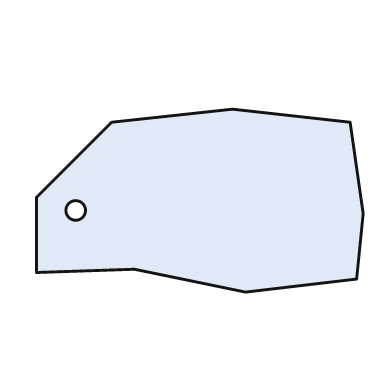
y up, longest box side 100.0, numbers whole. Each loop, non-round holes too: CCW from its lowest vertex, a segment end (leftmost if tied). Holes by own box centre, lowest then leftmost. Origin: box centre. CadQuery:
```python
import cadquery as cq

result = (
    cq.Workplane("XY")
    .moveTo(14.0, -28.0)
    .lineTo(48.0, -24.0)
    .lineTo(50.0, -4.0)
    .lineTo(46.0, 24.0)
    .lineTo(10.0, 28.0)
    .lineTo(-27.0, 24.0)
    .lineTo(-50.0, 1.0)
    .lineTo(-50.0, -22.0)
    .lineTo(-20.0, -21.0)
    .close()
    .moveTo(-38.0, -3.0)
    .circle(3.0)
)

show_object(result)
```